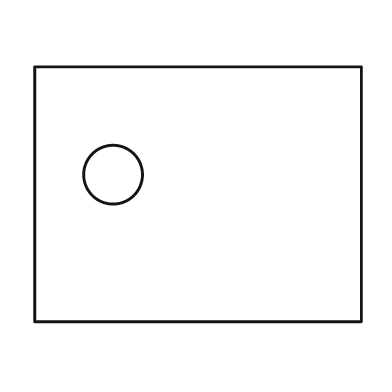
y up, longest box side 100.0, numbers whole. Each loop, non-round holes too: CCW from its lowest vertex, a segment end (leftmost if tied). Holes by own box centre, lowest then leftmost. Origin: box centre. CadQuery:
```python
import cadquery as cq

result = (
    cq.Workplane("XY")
    .moveTo(-50.0, -39.0)
    .lineTo(50.0, -39.0)
    .lineTo(50.0, 39.0)
    .lineTo(-50.0, 39.0)
    .close()
    .moveTo(-26.0, 6.0)
    .circle(9.0)
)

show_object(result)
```